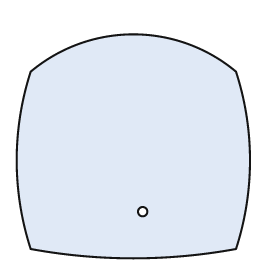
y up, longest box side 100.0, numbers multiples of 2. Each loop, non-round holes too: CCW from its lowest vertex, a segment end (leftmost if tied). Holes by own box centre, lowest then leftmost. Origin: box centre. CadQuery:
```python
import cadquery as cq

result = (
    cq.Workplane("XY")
    .moveTo(-44.0, -44.0)
    .threePointArc((0.0, -48.0), (44.0, -44.0))
    .threePointArc((50.0, -6.0), (44.0, 32.0))
    .threePointArc((0.0, 48.0), (-44.0, 32.0))
    .threePointArc((-50.0, -6.0), (-44.0, -44.0))
    .close()
    .moveTo(4.0, -28.0)
    .circle(2.0)
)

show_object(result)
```